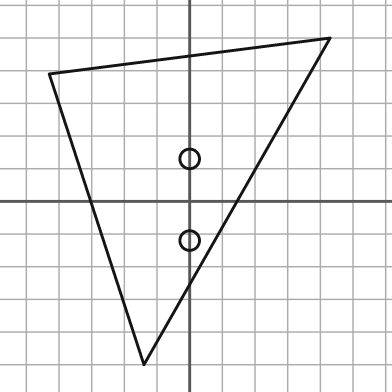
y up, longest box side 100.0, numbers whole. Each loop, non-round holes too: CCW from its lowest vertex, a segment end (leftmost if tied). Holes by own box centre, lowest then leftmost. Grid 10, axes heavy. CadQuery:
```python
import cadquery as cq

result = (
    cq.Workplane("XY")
    .moveTo(-14.0, -50.0)
    .lineTo(43.0, 50.0)
    .lineTo(-43.0, 39.0)
    .close()
    .moveTo(0.0, -12.0)
    .circle(3.0)
    .moveTo(0.0, 13.0)
    .circle(3.0)
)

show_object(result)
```